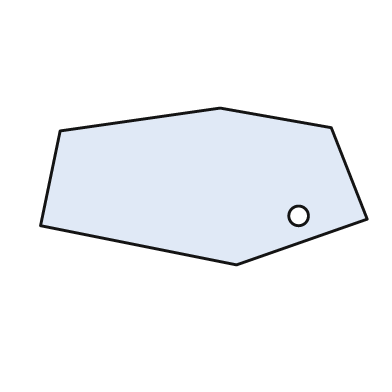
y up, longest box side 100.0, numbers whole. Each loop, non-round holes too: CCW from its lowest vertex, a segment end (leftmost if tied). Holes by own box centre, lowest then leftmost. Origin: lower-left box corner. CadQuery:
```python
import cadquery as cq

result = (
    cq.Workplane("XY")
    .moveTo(60.0, 0.0)
    .lineTo(100.0, 14.0)
    .lineTo(89.0, 42.0)
    .lineTo(55.0, 48.0)
    .lineTo(6.0, 41.0)
    .lineTo(0.0, 12.0)
    .close()
    .moveTo(79.0, 15.0)
    .circle(3.0)
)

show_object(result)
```